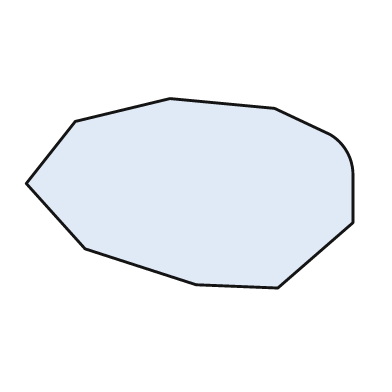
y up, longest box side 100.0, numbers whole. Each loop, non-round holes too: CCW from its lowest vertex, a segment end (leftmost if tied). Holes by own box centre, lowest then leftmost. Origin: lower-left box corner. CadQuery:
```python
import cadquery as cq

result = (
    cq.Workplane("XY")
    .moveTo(77.0, 0.0)
    .lineTo(100.0, 20.0)
    .lineTo(100.0, 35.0)
    .threePointArc((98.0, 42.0), (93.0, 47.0))
    .lineTo(76.0, 55.0)
    .lineTo(44.0, 58.0)
    .lineTo(15.0, 51.0)
    .lineTo(0.0, 32.0)
    .lineTo(18.0, 12.0)
    .lineTo(52.0, 1.0)
    .close()
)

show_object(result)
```